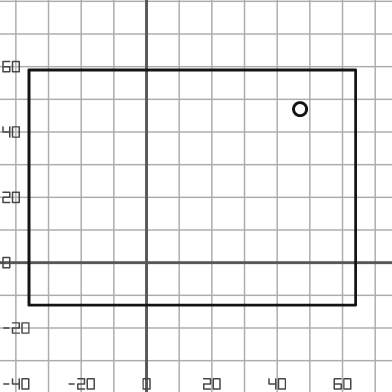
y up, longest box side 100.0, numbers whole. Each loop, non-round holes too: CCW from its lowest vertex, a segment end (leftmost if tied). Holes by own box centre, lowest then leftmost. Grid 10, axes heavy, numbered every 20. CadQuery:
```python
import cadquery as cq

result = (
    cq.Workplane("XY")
    .moveTo(-36.0, -13.0)
    .lineTo(64.0, -13.0)
    .lineTo(64.0, 59.0)
    .lineTo(-36.0, 59.0)
    .close()
    .moveTo(47.0, 47.0)
    .circle(2.0)
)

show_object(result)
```